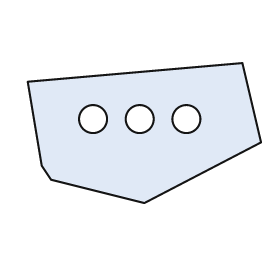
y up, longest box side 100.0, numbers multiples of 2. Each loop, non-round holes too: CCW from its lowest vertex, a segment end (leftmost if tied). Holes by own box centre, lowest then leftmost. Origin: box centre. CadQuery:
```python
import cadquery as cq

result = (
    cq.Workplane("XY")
    .moveTo(0.0, -30.0)
    .lineTo(50.0, -4.0)
    .lineTo(42.0, 30.0)
    .lineTo(-50.0, 22.0)
    .lineTo(-44.0, -14.0)
    .lineTo(-40.0, -20.0)
    .close()
    .moveTo(-22.0, 6.0)
    .circle(6.0)
    .moveTo(-2.0, 6.0)
    .circle(6.0)
    .moveTo(18.0, 6.0)
    .circle(6.0)
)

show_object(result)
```